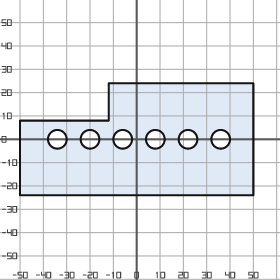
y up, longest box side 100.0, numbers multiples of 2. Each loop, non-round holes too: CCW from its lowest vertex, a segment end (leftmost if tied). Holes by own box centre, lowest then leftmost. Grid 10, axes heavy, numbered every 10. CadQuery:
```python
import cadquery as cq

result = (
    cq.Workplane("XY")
    .moveTo(-50.0, -24.0)
    .lineTo(50.0, -24.0)
    .lineTo(50.0, 24.0)
    .lineTo(-12.0, 24.0)
    .lineTo(-12.0, 8.0)
    .lineTo(-50.0, 8.0)
    .close()
    .moveTo(-34.0, 0.0)
    .circle(4.0)
    .moveTo(-20.0, 0.0)
    .circle(4.0)
    .moveTo(-6.0, 0.0)
    .circle(4.0)
    .moveTo(8.0, 0.0)
    .circle(4.0)
    .moveTo(22.0, 0.0)
    .circle(4.0)
    .moveTo(36.0, 0.0)
    .circle(4.0)
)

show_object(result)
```